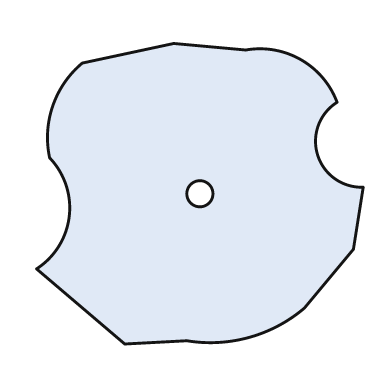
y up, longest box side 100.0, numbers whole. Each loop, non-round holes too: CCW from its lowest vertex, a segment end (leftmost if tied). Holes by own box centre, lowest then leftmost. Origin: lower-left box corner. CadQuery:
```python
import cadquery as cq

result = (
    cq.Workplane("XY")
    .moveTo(27.0, 0.0)
    .lineTo(46.0, 1.0)
    .threePointArc((65.0, 2.0), (82.0, 11.0))
    .lineTo(97.0, 29.0)
    .lineTo(100.0, 48.0)
    .threePointArc((86.0, 58.0), (92.0, 74.0))
    .threePointArc((81.0, 87.0), (64.0, 90.0))
    .lineTo(42.0, 92.0)
    .lineTo(14.0, 86.0)
    .threePointArc((5.0, 73.0), (4.0, 57.0))
    .threePointArc((10.0, 39.0), (0.0, 23.0))
    .close()
    .moveTo(50.0, 46.0)
    .circle(4.0)
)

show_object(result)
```